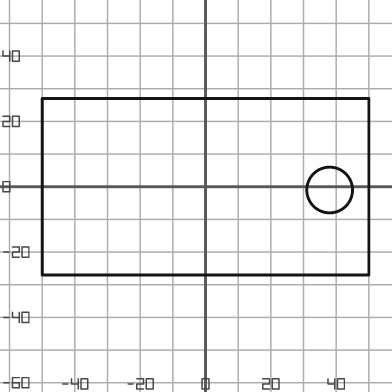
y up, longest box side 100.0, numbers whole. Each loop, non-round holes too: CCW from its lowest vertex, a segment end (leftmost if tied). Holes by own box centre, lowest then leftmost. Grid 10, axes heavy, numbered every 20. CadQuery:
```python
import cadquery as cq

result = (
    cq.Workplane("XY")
    .moveTo(-50.0, -27.0)
    .lineTo(50.0, -27.0)
    .lineTo(50.0, 27.0)
    .lineTo(-50.0, 27.0)
    .close()
    .moveTo(38.0, -1.0)
    .circle(7.0)
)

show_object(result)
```